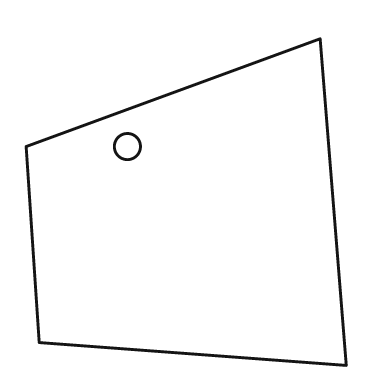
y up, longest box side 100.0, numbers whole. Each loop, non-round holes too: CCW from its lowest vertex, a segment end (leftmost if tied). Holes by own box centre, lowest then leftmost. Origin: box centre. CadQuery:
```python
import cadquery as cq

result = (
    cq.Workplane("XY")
    .moveTo(49.0, -50.0)
    .lineTo(41.0, 50.0)
    .lineTo(-49.0, 17.0)
    .lineTo(-45.0, -43.0)
    .close()
    .moveTo(-18.0, 17.0)
    .circle(4.0)
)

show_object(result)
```